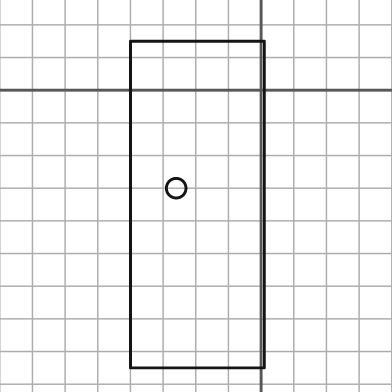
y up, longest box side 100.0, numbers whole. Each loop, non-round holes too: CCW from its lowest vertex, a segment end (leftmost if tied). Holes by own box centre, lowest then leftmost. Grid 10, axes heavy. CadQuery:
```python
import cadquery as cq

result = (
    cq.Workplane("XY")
    .moveTo(-40.0, -85.0)
    .lineTo(1.0, -85.0)
    .lineTo(1.0, 15.0)
    .lineTo(-40.0, 15.0)
    .close()
    .moveTo(-26.0, -30.0)
    .circle(3.0)
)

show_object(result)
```